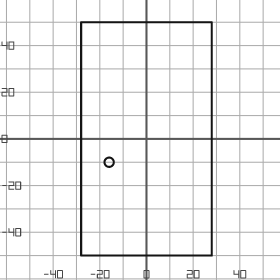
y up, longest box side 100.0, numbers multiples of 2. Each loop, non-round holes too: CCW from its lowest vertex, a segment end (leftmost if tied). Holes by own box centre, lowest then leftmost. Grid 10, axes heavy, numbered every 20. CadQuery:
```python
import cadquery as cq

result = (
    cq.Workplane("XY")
    .moveTo(-28.0, -50.0)
    .lineTo(28.0, -50.0)
    .lineTo(28.0, 50.0)
    .lineTo(-28.0, 50.0)
    .close()
    .moveTo(-16.0, -10.0)
    .circle(2.0)
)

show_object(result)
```